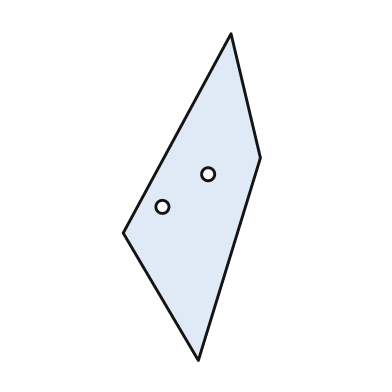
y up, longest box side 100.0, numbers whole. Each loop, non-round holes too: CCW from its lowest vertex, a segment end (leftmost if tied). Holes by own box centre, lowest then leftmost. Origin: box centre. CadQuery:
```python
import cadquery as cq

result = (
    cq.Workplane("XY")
    .moveTo(2.0, -50.0)
    .lineTo(21.0, 12.0)
    .lineTo(12.0, 50.0)
    .lineTo(-21.0, -11.0)
    .close()
    .moveTo(-9.0, -3.0)
    .circle(2.0)
    .moveTo(5.0, 7.0)
    .circle(2.0)
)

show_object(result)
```